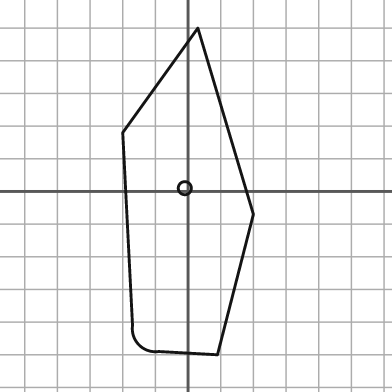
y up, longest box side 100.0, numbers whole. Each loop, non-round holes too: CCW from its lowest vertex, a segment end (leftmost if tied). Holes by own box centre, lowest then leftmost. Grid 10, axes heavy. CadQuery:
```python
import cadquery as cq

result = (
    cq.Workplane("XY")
    .moveTo(9.0, -50.0)
    .lineTo(20.0, -7.0)
    .lineTo(3.0, 50.0)
    .lineTo(-20.0, 18.0)
    .lineTo(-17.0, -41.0)
    .threePointArc((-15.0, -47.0), (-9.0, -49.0))
    .close()
    .moveTo(-1.0, 1.0)
    .circle(2.0)
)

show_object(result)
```